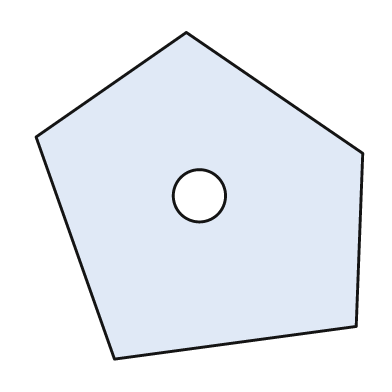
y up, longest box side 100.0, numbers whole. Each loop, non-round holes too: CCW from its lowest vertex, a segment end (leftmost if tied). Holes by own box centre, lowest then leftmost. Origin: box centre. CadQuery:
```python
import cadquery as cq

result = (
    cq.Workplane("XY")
    .moveTo(-26.0, -50.0)
    .lineTo(48.0, -40.0)
    .lineTo(50.0, 13.0)
    .lineTo(-4.0, 50.0)
    .lineTo(-50.0, 18.0)
    .close()
    .moveTo(0.0, 0.0)
    .circle(8.0)
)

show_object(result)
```